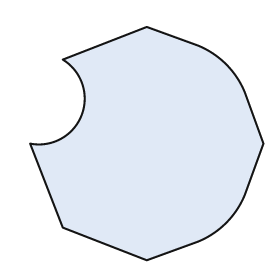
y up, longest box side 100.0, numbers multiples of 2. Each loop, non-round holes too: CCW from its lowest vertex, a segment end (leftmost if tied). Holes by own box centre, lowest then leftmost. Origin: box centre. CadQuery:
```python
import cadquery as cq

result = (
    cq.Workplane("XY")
    .moveTo(0.0, -50.0)
    .lineTo(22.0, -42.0)
    .threePointArc((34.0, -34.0), (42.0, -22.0))
    .lineTo(50.0, 0.0)
    .lineTo(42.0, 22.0)
    .threePointArc((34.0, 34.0), (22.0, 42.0))
    .lineTo(0.0, 50.0)
    .lineTo(-36.0, 36.0)
    .threePointArc((-28.0, 12.0), (-50.0, 0.0))
    .lineTo(-36.0, -36.0)
    .close()
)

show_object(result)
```